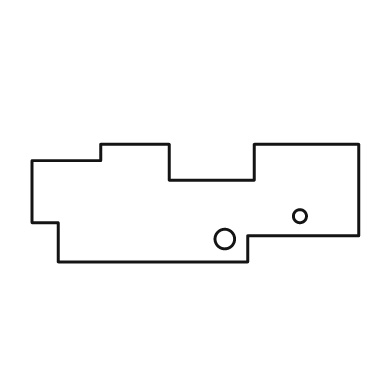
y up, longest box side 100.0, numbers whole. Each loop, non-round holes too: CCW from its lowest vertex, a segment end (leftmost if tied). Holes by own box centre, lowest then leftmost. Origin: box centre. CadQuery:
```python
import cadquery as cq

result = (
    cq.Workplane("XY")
    .moveTo(-42.0, -18.0)
    .lineTo(16.0, -18.0)
    .lineTo(16.0, -10.0)
    .lineTo(50.0, -10.0)
    .lineTo(50.0, 18.0)
    .lineTo(18.0, 18.0)
    .lineTo(18.0, 7.0)
    .lineTo(-8.0, 7.0)
    .lineTo(-8.0, 18.0)
    .lineTo(-29.0, 18.0)
    .lineTo(-29.0, 13.0)
    .lineTo(-50.0, 13.0)
    .lineTo(-50.0, -6.0)
    .lineTo(-42.0, -6.0)
    .close()
    .moveTo(9.0, -11.0)
    .circle(3.0)
    .moveTo(32.0, -4.0)
    .circle(2.0)
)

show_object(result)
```